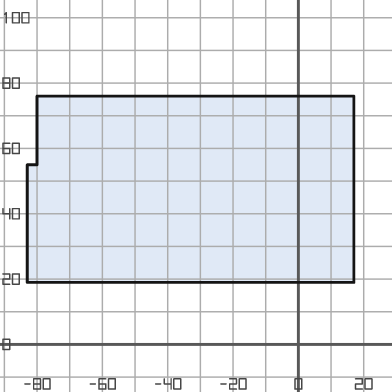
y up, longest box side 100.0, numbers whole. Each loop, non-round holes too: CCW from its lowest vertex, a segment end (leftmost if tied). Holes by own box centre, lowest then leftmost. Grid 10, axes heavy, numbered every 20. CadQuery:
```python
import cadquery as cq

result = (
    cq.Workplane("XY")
    .moveTo(-83.0, 19.0)
    .lineTo(17.0, 19.0)
    .lineTo(17.0, 76.0)
    .lineTo(-80.0, 76.0)
    .lineTo(-80.0, 55.0)
    .lineTo(-83.0, 55.0)
    .close()
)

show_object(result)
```